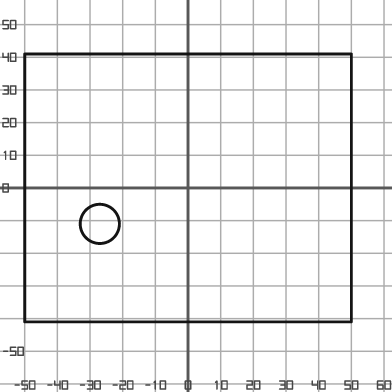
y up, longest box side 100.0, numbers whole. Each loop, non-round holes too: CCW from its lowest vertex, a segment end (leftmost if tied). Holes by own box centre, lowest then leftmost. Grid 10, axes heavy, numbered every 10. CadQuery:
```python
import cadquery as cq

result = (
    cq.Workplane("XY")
    .moveTo(-50.0, -41.0)
    .lineTo(50.0, -41.0)
    .lineTo(50.0, 41.0)
    .lineTo(-50.0, 41.0)
    .close()
    .moveTo(-27.0, -11.0)
    .circle(6.0)
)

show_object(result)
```